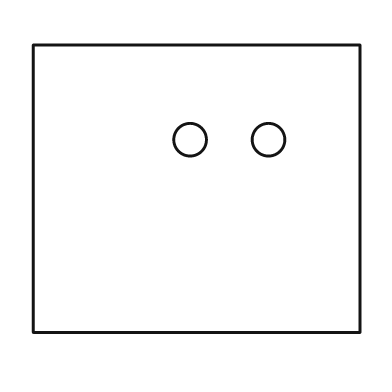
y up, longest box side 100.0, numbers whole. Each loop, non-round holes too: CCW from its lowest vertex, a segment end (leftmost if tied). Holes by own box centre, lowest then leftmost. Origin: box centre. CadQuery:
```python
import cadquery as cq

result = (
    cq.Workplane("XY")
    .moveTo(-50.0, -44.0)
    .lineTo(50.0, -44.0)
    .lineTo(50.0, 44.0)
    .lineTo(-50.0, 44.0)
    .close()
    .moveTo(-2.0, 15.0)
    .circle(5.0)
    .moveTo(22.0, 15.0)
    .circle(5.0)
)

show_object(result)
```